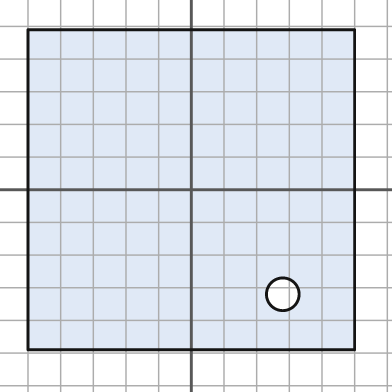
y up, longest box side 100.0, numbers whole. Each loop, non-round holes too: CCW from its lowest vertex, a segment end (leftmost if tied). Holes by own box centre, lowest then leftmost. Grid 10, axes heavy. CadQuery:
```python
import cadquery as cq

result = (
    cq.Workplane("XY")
    .moveTo(-50.0, -49.0)
    .lineTo(50.0, -49.0)
    .lineTo(50.0, 49.0)
    .lineTo(-50.0, 49.0)
    .close()
    .moveTo(28.0, -32.0)
    .circle(5.0)
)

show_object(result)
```